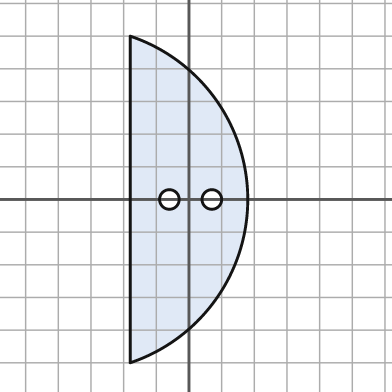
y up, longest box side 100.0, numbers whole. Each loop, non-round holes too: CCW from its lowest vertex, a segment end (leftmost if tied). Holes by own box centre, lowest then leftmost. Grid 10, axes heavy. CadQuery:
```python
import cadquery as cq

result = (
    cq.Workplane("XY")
    .moveTo(-18.0, -50.0)
    .threePointArc((18.0, 0.0), (-18.0, 50.0))
    .close()
    .moveTo(-6.0, 0.0)
    .circle(3.0)
    .moveTo(7.0, 0.0)
    .circle(3.0)
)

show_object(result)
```